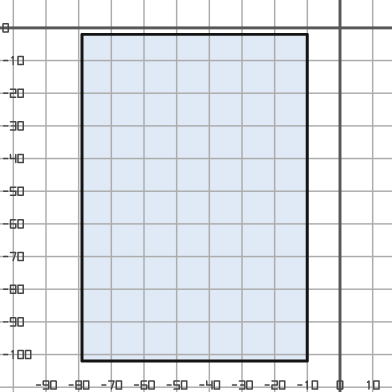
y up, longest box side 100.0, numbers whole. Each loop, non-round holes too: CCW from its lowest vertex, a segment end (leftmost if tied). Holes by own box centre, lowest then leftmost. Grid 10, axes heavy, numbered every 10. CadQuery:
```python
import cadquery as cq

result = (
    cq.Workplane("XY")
    .moveTo(-79.0, -102.0)
    .lineTo(-10.0, -102.0)
    .lineTo(-10.0, -2.0)
    .lineTo(-79.0, -2.0)
    .close()
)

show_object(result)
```